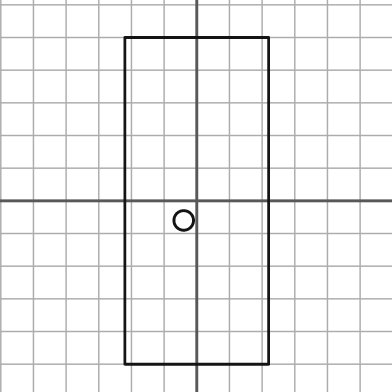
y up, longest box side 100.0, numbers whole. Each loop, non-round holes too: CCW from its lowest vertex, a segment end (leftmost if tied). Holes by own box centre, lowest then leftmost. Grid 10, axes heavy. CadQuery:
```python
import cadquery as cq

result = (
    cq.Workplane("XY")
    .moveTo(-22.0, -50.0)
    .lineTo(22.0, -50.0)
    .lineTo(22.0, 50.0)
    .lineTo(-22.0, 50.0)
    .close()
    .moveTo(-4.0, -6.0)
    .circle(3.0)
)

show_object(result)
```